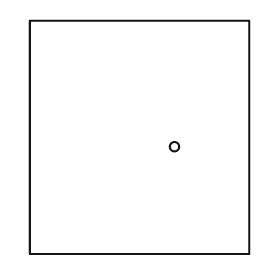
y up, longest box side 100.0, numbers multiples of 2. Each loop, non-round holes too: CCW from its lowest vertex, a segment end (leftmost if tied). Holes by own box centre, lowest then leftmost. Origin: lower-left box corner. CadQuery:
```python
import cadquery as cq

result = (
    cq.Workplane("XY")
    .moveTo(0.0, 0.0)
    .lineTo(94.0, 0.0)
    .lineTo(94.0, 100.0)
    .lineTo(0.0, 100.0)
    .close()
    .moveTo(62.0, 46.0)
    .circle(2.0)
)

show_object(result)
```